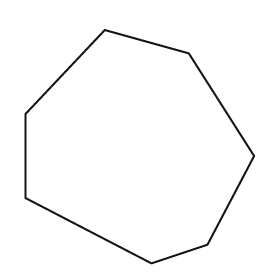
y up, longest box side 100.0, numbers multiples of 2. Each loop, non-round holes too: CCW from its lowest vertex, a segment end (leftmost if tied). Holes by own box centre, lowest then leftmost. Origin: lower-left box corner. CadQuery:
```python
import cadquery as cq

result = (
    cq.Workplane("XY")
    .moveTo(54.0, 0.0)
    .lineTo(78.0, 8.0)
    .lineTo(98.0, 46.0)
    .lineTo(70.0, 90.0)
    .lineTo(34.0, 100.0)
    .lineTo(0.0, 64.0)
    .lineTo(0.0, 28.0)
    .close()
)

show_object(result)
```